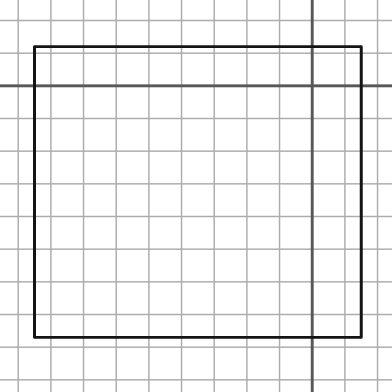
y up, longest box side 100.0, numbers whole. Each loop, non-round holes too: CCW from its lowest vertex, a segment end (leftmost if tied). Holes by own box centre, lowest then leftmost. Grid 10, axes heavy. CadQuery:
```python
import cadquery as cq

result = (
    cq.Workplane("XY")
    .moveTo(-85.0, -77.0)
    .lineTo(15.0, -77.0)
    .lineTo(15.0, 12.0)
    .lineTo(-85.0, 12.0)
    .close()
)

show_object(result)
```